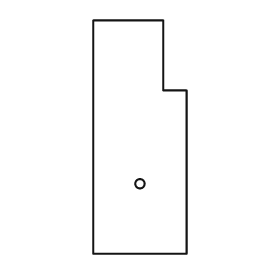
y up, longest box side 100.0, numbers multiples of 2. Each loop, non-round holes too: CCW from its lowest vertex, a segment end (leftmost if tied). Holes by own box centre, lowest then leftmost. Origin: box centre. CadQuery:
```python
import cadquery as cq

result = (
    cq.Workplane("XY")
    .moveTo(-20.0, -50.0)
    .lineTo(20.0, -50.0)
    .lineTo(20.0, 20.0)
    .lineTo(10.0, 20.0)
    .lineTo(10.0, 50.0)
    .lineTo(-20.0, 50.0)
    .close()
    .moveTo(0.0, -20.0)
    .circle(2.0)
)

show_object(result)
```